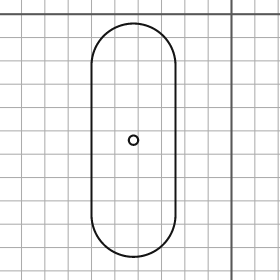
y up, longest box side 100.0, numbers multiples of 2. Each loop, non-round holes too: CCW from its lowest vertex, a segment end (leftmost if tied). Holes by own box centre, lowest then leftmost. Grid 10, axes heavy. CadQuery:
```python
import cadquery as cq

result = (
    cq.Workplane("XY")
    .moveTo(-60.0, -86.0)
    .threePointArc((-42.0, -104.0), (-24.0, -86.0))
    .lineTo(-24.0, -22.0)
    .threePointArc((-42.0, -4.0), (-60.0, -22.0))
    .close()
    .moveTo(-42.0, -54.0)
    .circle(2.0)
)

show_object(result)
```